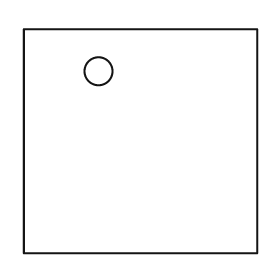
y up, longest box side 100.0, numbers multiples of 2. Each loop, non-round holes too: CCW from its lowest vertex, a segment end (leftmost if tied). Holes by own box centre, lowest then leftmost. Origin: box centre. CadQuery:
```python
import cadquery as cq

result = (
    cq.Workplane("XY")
    .moveTo(-50.0, -48.0)
    .lineTo(50.0, -48.0)
    .lineTo(50.0, 48.0)
    .lineTo(-50.0, 48.0)
    .close()
    .moveTo(-18.0, 30.0)
    .circle(6.0)
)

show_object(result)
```